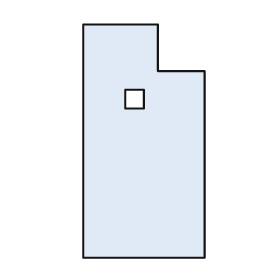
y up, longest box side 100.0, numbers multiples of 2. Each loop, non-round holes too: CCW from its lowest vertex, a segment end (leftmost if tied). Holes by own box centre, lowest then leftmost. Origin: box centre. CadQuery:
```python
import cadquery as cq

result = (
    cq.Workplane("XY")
    .moveTo(-26.0, -50.0)
    .lineTo(26.0, -50.0)
    .lineTo(26.0, 30.0)
    .lineTo(6.0, 30.0)
    .lineTo(6.0, 50.0)
    .lineTo(-26.0, 50.0)
    .close()
    .moveTo(-8.0, 14.0)
    .lineTo(0.0, 14.0)
    .lineTo(0.0, 22.0)
    .lineTo(-8.0, 22.0)
    .close()
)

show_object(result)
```